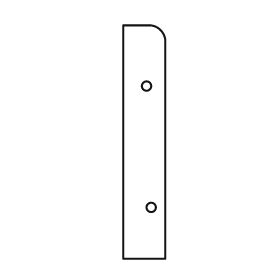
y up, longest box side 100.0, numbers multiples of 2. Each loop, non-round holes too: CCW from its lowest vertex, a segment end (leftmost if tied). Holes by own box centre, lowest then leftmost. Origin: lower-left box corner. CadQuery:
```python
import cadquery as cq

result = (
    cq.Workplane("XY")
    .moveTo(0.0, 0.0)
    .lineTo(18.0, 0.0)
    .lineTo(18.0, 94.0)
    .threePointArc((16.0, 98.0), (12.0, 100.0))
    .lineTo(0.0, 100.0)
    .close()
    .moveTo(12.0, 22.0)
    .circle(2.0)
    .moveTo(10.0, 74.0)
    .circle(2.0)
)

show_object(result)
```